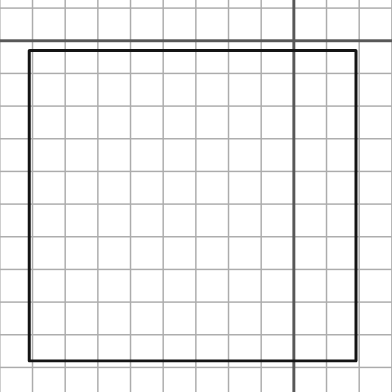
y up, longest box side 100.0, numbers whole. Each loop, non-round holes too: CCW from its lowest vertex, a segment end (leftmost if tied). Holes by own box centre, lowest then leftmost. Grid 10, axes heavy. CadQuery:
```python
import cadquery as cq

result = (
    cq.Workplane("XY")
    .moveTo(-81.0, -98.0)
    .lineTo(19.0, -98.0)
    .lineTo(19.0, -3.0)
    .lineTo(-81.0, -3.0)
    .close()
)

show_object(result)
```